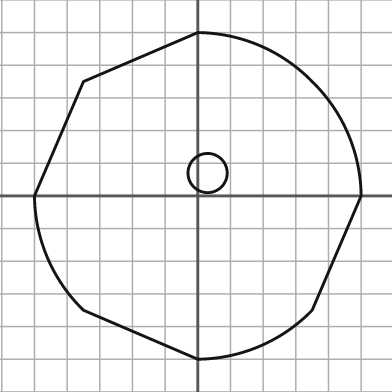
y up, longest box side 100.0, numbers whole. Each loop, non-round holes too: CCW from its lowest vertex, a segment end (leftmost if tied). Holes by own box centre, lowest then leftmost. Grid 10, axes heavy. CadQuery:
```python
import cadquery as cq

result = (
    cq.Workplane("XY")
    .moveTo(0.0, -50.0)
    .threePointArc((19.0, -46.0), (35.0, -35.0))
    .lineTo(50.0, 0.0)
    .threePointArc((46.0, 19.0), (35.0, 35.0))
    .threePointArc((19.0, 46.0), (0.0, 50.0))
    .lineTo(-35.0, 35.0)
    .lineTo(-50.0, 0.0)
    .threePointArc((-46.0, -19.0), (-35.0, -35.0))
    .close()
    .moveTo(3.0, 7.0)
    .circle(6.0)
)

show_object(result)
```